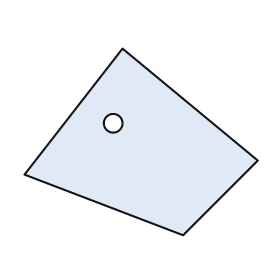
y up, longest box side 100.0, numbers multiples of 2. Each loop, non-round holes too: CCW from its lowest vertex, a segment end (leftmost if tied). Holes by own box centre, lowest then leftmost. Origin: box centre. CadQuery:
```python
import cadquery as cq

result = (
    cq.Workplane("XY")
    .moveTo(18.0, -40.0)
    .lineTo(50.0, -8.0)
    .lineTo(-8.0, 40.0)
    .lineTo(-50.0, -14.0)
    .close()
    .moveTo(-12.0, 8.0)
    .circle(4.0)
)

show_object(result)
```